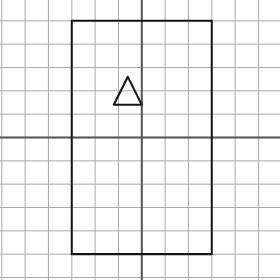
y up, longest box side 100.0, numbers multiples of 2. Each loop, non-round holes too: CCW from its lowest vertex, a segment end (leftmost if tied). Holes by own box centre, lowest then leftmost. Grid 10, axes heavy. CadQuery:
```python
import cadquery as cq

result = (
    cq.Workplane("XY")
    .moveTo(-30.0, -50.0)
    .lineTo(30.0, -50.0)
    .lineTo(30.0, 50.0)
    .lineTo(-30.0, 50.0)
    .close()
    .moveTo(-12.0, 14.0)
    .lineTo(0.0, 14.0)
    .lineTo(-6.0, 26.0)
    .close()
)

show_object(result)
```